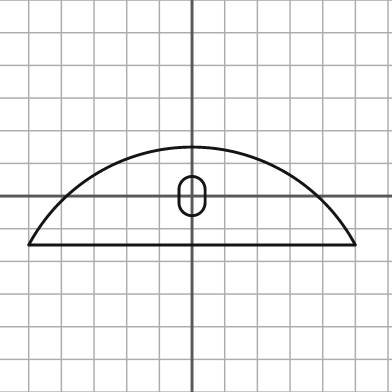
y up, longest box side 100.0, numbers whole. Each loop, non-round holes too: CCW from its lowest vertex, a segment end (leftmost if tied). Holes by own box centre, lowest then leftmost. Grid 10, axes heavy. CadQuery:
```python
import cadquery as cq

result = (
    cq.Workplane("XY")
    .moveTo(-50.0, -15.0)
    .lineTo(50.0, -15.0)
    .threePointArc((0.0, 15.0), (-50.0, -15.0))
    .close()
    .moveTo(-4.0, -2.0)
    .threePointArc((0.0, -6.0), (4.0, -2.0))
    .lineTo(4.0, 2.0)
    .threePointArc((0.0, 6.0), (-4.0, 2.0))
    .close()
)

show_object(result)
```